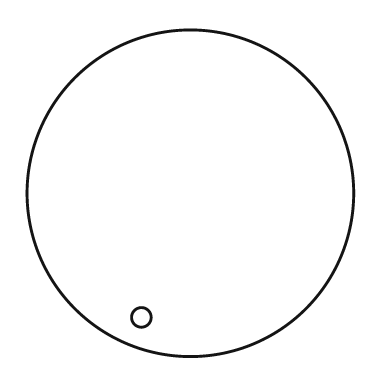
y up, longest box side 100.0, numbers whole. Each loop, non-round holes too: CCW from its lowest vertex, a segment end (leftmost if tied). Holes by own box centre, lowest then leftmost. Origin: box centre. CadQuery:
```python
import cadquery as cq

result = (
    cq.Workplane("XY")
    .moveTo(0.0, 0.0)
    .circle(50.0)
    .moveTo(-15.0, -38.0)
    .circle(3.0)
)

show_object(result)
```